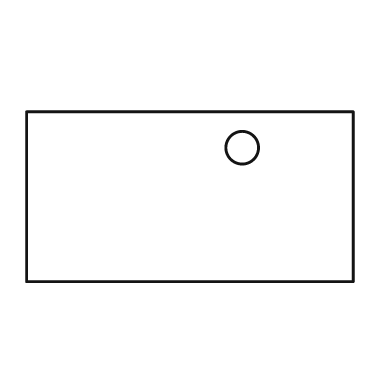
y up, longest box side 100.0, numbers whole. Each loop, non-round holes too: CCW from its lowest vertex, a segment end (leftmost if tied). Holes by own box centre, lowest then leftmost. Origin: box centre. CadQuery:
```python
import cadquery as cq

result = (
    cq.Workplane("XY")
    .moveTo(-50.0, -26.0)
    .lineTo(50.0, -26.0)
    .lineTo(50.0, 26.0)
    .lineTo(-50.0, 26.0)
    .close()
    .moveTo(16.0, 15.0)
    .circle(5.0)
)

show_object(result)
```